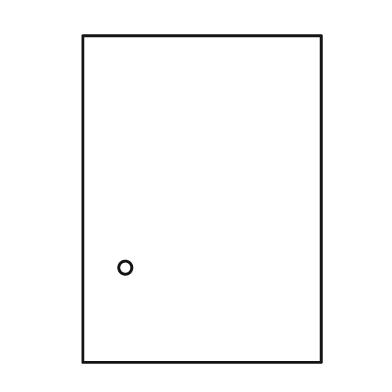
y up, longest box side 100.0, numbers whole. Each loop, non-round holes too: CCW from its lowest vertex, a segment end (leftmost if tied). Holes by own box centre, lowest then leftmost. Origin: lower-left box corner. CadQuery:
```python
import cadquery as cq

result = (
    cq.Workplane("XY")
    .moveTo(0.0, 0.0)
    .lineTo(73.0, 0.0)
    .lineTo(73.0, 100.0)
    .lineTo(0.0, 100.0)
    .close()
    .moveTo(13.0, 29.0)
    .circle(2.0)
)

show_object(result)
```